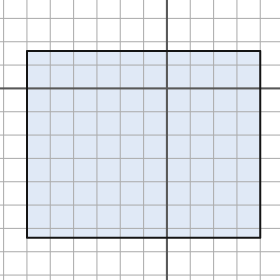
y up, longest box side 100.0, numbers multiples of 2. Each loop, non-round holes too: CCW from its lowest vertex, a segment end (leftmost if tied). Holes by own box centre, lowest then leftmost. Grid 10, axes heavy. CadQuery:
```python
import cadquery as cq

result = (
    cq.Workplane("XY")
    .moveTo(-60.0, -64.0)
    .lineTo(40.0, -64.0)
    .lineTo(40.0, 16.0)
    .lineTo(-60.0, 16.0)
    .close()
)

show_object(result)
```